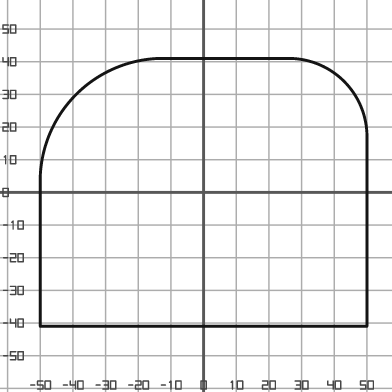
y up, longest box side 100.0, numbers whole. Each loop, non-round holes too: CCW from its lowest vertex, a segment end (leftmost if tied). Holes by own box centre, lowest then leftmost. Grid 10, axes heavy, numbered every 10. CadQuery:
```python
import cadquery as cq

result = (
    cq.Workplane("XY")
    .moveTo(-50.0, -41.0)
    .lineTo(50.0, -41.0)
    .lineTo(50.0, 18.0)
    .threePointArc((43.0, 34.0), (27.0, 41.0))
    .lineTo(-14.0, 41.0)
    .threePointArc((-39.0, 30.0), (-50.0, 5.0))
    .close()
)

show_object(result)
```